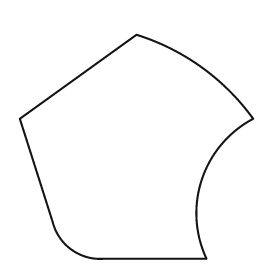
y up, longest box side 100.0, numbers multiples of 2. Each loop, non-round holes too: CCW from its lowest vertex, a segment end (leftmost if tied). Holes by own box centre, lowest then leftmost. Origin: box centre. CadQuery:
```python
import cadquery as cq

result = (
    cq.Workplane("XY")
    .moveTo(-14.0, -48.0)
    .lineTo(30.0, -48.0)
    .threePointArc((28.0, -14.0), (50.0, 12.0))
    .threePointArc((28.0, 34.0), (0.0, 48.0))
    .lineTo(-50.0, 12.0)
    .lineTo(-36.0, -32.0)
    .threePointArc((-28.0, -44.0), (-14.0, -48.0))
    .close()
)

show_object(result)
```